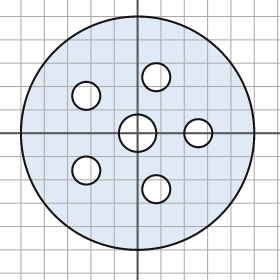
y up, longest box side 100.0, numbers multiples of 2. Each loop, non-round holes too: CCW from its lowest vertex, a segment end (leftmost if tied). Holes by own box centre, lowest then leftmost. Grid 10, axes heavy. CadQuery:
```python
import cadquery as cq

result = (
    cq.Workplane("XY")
    .moveTo(0.0, 0.0)
    .circle(50.0)
    .moveTo(8.0, -24.0)
    .circle(6.0)
    .moveTo(-22.0, -16.0)
    .circle(6.0)
    .moveTo(0.0, 0.0)
    .circle(8.0)
    .moveTo(26.0, 0.0)
    .circle(6.0)
    .moveTo(-22.0, 16.0)
    .circle(6.0)
    .moveTo(8.0, 24.0)
    .circle(6.0)
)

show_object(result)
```